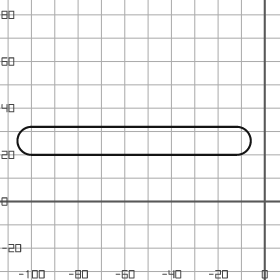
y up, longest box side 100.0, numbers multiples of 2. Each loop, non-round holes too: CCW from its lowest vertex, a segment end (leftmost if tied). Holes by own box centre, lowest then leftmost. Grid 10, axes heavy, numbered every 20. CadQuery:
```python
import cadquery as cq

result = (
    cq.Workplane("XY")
    .moveTo(-100.0, 20.0)
    .lineTo(-12.0, 20.0)
    .threePointArc((-6.0, 26.0), (-12.0, 32.0))
    .lineTo(-100.0, 32.0)
    .threePointArc((-106.0, 26.0), (-100.0, 20.0))
    .close()
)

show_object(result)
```